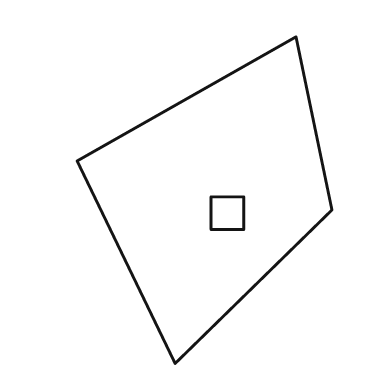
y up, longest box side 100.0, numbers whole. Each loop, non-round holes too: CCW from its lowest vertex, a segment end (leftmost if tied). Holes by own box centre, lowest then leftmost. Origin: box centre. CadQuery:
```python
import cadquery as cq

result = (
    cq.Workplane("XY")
    .moveTo(-9.0, -50.0)
    .lineTo(39.0, -3.0)
    .lineTo(28.0, 50.0)
    .lineTo(-39.0, 12.0)
    .close()
    .moveTo(2.0, -9.0)
    .lineTo(12.0, -9.0)
    .lineTo(12.0, 1.0)
    .lineTo(2.0, 1.0)
    .close()
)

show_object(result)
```